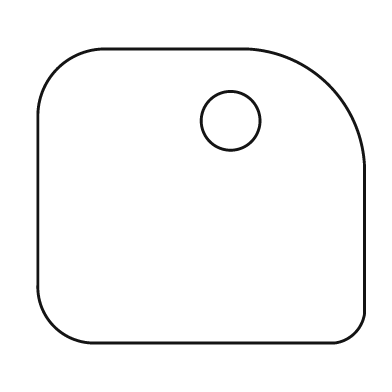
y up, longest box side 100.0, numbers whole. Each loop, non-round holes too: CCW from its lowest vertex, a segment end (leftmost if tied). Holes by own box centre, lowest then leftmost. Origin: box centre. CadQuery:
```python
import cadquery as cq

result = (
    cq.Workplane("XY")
    .moveTo(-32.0, -45.0)
    .lineTo(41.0, -45.0)
    .threePointArc((47.0, -42.0), (50.0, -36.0))
    .lineTo(50.0, 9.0)
    .threePointArc((39.0, 34.0), (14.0, 45.0))
    .lineTo(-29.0, 45.0)
    .threePointArc((-44.0, 39.0), (-50.0, 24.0))
    .lineTo(-50.0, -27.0)
    .threePointArc((-45.0, -40.0), (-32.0, -45.0))
    .close()
    .moveTo(9.0, 23.0)
    .circle(9.0)
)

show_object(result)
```